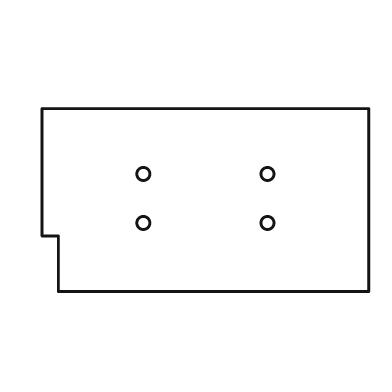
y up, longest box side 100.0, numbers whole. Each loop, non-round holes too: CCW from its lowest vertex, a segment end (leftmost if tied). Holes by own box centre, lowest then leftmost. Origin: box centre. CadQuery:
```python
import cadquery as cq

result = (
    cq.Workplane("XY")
    .moveTo(-45.0, -28.0)
    .lineTo(50.0, -28.0)
    .lineTo(50.0, 28.0)
    .lineTo(-50.0, 28.0)
    .lineTo(-50.0, -11.0)
    .lineTo(-45.0, -11.0)
    .close()
    .moveTo(-19.0, -7.0)
    .circle(2.0)
    .moveTo(19.0, -7.0)
    .circle(2.0)
    .moveTo(-19.0, 8.0)
    .circle(2.0)
    .moveTo(19.0, 8.0)
    .circle(2.0)
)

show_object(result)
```